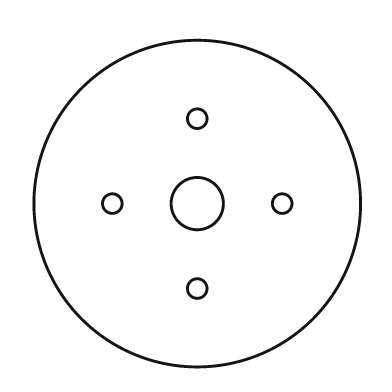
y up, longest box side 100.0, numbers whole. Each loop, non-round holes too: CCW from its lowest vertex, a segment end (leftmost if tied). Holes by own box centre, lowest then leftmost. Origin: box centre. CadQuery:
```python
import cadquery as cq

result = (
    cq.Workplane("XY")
    .moveTo(0.0, 0.0)
    .circle(50.0)
    .moveTo(0.0, -26.0)
    .circle(3.0)
    .moveTo(-26.0, 0.0)
    .circle(3.0)
    .moveTo(0.0, 0.0)
    .circle(8.0)
    .moveTo(26.0, 0.0)
    .circle(3.0)
    .moveTo(0.0, 26.0)
    .circle(3.0)
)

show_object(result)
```